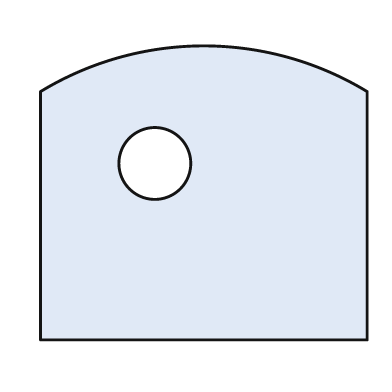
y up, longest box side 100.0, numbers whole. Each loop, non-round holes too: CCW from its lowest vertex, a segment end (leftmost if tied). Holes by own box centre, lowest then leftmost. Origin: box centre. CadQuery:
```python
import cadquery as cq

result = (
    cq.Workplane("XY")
    .moveTo(-50.0, -45.0)
    .lineTo(50.0, -45.0)
    .lineTo(50.0, 31.0)
    .threePointArc((0.0, 45.0), (-50.0, 31.0))
    .close()
    .moveTo(-15.0, 9.0)
    .circle(11.0)
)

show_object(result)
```